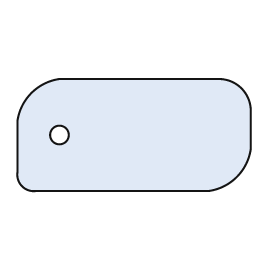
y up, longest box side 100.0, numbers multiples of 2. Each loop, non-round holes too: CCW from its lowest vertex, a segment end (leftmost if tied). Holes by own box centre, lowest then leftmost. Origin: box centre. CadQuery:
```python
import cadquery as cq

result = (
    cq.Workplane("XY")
    .moveTo(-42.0, -24.0)
    .lineTo(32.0, -24.0)
    .threePointArc((44.0, -18.0), (50.0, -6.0))
    .lineTo(50.0, 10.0)
    .threePointArc((46.0, 20.0), (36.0, 24.0))
    .lineTo(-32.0, 24.0)
    .threePointArc((-44.0, 18.0), (-50.0, 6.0))
    .lineTo(-50.0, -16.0)
    .threePointArc((-48.0, -22.0), (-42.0, -24.0))
    .close()
    .moveTo(-32.0, 0.0)
    .circle(4.0)
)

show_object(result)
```